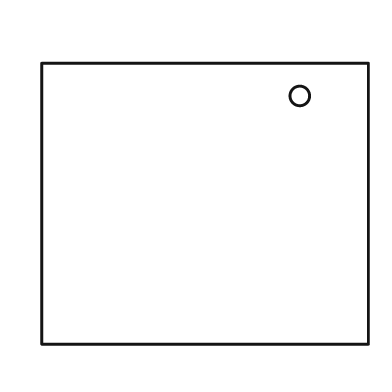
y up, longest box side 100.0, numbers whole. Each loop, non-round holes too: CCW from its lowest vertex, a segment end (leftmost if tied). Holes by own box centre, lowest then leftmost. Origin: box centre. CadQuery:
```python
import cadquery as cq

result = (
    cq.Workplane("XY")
    .moveTo(-50.0, -43.0)
    .lineTo(50.0, -43.0)
    .lineTo(50.0, 43.0)
    .lineTo(-50.0, 43.0)
    .close()
    .moveTo(29.0, 33.0)
    .circle(3.0)
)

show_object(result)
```